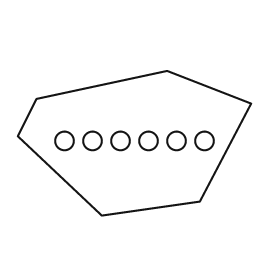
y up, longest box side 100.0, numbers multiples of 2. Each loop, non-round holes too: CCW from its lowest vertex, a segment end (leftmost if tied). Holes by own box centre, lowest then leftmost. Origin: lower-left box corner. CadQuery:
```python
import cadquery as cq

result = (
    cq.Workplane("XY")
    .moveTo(36.0, 0.0)
    .lineTo(78.0, 6.0)
    .lineTo(100.0, 48.0)
    .lineTo(64.0, 62.0)
    .lineTo(8.0, 50.0)
    .lineTo(0.0, 34.0)
    .close()
    .moveTo(20.0, 32.0)
    .circle(4.0)
    .moveTo(32.0, 32.0)
    .circle(4.0)
    .moveTo(44.0, 32.0)
    .circle(4.0)
    .moveTo(56.0, 32.0)
    .circle(4.0)
    .moveTo(68.0, 32.0)
    .circle(4.0)
    .moveTo(80.0, 32.0)
    .circle(4.0)
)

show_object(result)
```